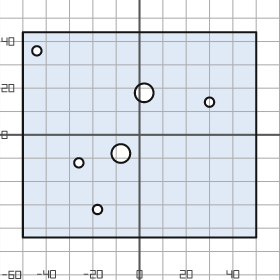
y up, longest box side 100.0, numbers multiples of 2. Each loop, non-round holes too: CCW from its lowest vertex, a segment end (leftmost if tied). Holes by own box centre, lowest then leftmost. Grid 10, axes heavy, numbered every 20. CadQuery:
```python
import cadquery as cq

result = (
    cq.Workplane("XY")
    .moveTo(-50.0, -44.0)
    .lineTo(50.0, -44.0)
    .lineTo(50.0, 44.0)
    .lineTo(-50.0, 44.0)
    .close()
    .moveTo(-18.0, -32.0)
    .circle(2.0)
    .moveTo(-26.0, -12.0)
    .circle(2.0)
    .moveTo(-8.0, -8.0)
    .circle(4.0)
    .moveTo(30.0, 14.0)
    .circle(2.0)
    .moveTo(2.0, 18.0)
    .circle(4.0)
    .moveTo(-44.0, 36.0)
    .circle(2.0)
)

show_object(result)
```